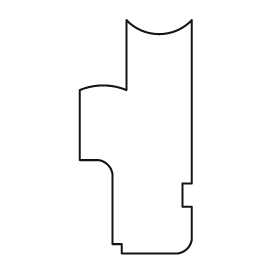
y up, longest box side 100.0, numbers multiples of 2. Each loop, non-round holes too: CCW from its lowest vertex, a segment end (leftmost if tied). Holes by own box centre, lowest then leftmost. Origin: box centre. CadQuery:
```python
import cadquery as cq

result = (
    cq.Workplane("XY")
    .moveTo(-6.0, -50.0)
    .lineTo(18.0, -50.0)
    .threePointArc((22.0, -48.0), (24.0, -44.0))
    .lineTo(24.0, -30.0)
    .lineTo(20.0, -30.0)
    .lineTo(20.0, -20.0)
    .lineTo(24.0, -20.0)
    .lineTo(24.0, 50.0)
    .threePointArc((10.0, 44.0), (-4.0, 50.0))
    .lineTo(-4.0, 20.0)
    .threePointArc((-14.0, 22.0), (-24.0, 20.0))
    .lineTo(-24.0, -10.0)
    .lineTo(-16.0, -10.0)
    .threePointArc((-12.0, -12.0), (-10.0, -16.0))
    .lineTo(-10.0, -46.0)
    .lineTo(-6.0, -46.0)
    .close()
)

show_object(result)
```